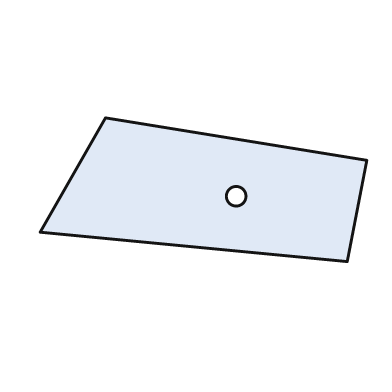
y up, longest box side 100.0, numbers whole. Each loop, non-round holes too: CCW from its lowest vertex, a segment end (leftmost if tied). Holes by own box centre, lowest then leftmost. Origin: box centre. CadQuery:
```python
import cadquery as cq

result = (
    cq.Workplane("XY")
    .moveTo(44.0, -22.0)
    .lineTo(50.0, 9.0)
    .lineTo(-30.0, 22.0)
    .lineTo(-50.0, -13.0)
    .close()
    .moveTo(10.0, -2.0)
    .circle(3.0)
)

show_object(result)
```